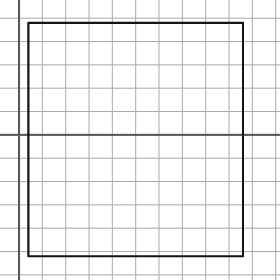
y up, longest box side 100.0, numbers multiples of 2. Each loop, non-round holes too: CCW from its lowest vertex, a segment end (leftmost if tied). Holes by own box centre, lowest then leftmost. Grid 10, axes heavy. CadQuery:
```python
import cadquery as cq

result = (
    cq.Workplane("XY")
    .moveTo(4.0, -52.0)
    .lineTo(96.0, -52.0)
    .lineTo(96.0, 48.0)
    .lineTo(4.0, 48.0)
    .close()
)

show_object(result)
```